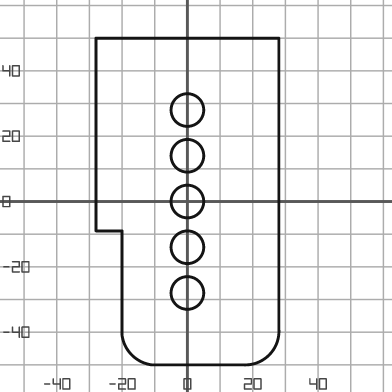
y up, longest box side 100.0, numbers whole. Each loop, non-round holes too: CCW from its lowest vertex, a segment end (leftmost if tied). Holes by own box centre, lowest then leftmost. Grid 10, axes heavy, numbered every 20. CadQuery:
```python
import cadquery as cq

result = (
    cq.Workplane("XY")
    .moveTo(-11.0, -50.0)
    .lineTo(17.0, -50.0)
    .threePointArc((25.0, -47.0), (28.0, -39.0))
    .lineTo(28.0, 50.0)
    .lineTo(-28.0, 50.0)
    .lineTo(-28.0, -9.0)
    .lineTo(-20.0, -9.0)
    .lineTo(-20.0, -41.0)
    .threePointArc((-17.0, -47.0), (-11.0, -50.0))
    .close()
    .moveTo(0.0, -28.0)
    .circle(5.0)
    .moveTo(0.0, -14.0)
    .circle(5.0)
    .moveTo(0.0, 0.0)
    .circle(5.0)
    .moveTo(0.0, 14.0)
    .circle(5.0)
    .moveTo(0.0, 28.0)
    .circle(5.0)
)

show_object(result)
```